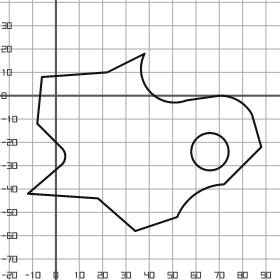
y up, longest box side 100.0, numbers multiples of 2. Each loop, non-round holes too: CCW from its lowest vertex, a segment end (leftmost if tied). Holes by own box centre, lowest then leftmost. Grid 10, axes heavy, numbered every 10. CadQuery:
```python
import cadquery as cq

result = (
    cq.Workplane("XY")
    .moveTo(34.0, -58.0)
    .lineTo(52.0, -52.0)
    .threePointArc((60.0, -42.0), (72.0, -38.0))
    .lineTo(88.0, -22.0)
    .lineTo(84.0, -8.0)
    .threePointArc((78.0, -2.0), (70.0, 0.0))
    .lineTo(56.0, -2.0)
    .threePointArc((40.0, 2.0), (38.0, 18.0))
    .lineTo(22.0, 10.0)
    .lineTo(-6.0, 8.0)
    .lineTo(-8.0, -12.0)
    .lineTo(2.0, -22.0)
    .threePointArc((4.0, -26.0), (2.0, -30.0))
    .lineTo(-12.0, -42.0)
    .lineTo(18.0, -44.0)
    .close()
    .moveTo(66.0, -24.0)
    .circle(8.0)
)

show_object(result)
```